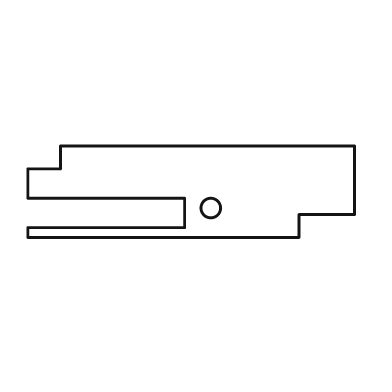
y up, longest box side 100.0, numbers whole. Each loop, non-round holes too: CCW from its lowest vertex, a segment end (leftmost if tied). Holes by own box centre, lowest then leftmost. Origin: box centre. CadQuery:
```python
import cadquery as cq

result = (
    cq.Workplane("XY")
    .moveTo(-50.0, -14.0)
    .lineTo(33.0, -14.0)
    .lineTo(33.0, -7.0)
    .lineTo(50.0, -7.0)
    .lineTo(50.0, 14.0)
    .lineTo(-40.0, 14.0)
    .lineTo(-40.0, 7.0)
    .lineTo(-50.0, 7.0)
    .lineTo(-50.0, -2.0)
    .lineTo(-2.0, -2.0)
    .lineTo(-2.0, -11.0)
    .lineTo(-50.0, -11.0)
    .close()
    .moveTo(6.0, -5.0)
    .circle(3.0)
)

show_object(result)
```